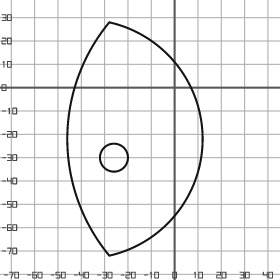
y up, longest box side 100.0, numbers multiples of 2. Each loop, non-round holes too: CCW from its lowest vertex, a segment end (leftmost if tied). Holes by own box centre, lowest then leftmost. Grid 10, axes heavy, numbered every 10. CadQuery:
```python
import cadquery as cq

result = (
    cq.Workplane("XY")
    .moveTo(-28.0, -72.0)
    .threePointArc((12.0, -22.0), (-28.0, 28.0))
    .threePointArc((-46.0, -22.0), (-28.0, -72.0))
    .close()
    .moveTo(-26.0, -30.0)
    .circle(6.0)
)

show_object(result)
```